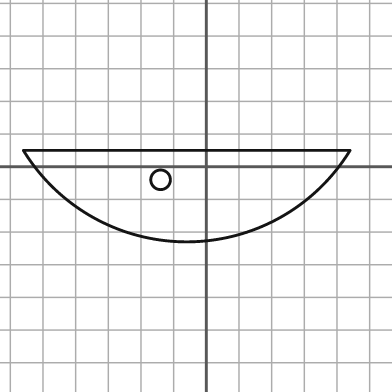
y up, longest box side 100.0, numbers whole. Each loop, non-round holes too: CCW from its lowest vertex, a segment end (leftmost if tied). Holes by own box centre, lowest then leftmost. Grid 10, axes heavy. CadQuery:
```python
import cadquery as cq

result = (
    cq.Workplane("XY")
    .moveTo(-56.0, 5.0)
    .threePointArc((-6.0, -23.0), (44.0, 5.0))
    .close()
    .moveTo(-14.0, -4.0)
    .circle(3.0)
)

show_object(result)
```